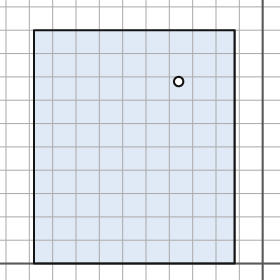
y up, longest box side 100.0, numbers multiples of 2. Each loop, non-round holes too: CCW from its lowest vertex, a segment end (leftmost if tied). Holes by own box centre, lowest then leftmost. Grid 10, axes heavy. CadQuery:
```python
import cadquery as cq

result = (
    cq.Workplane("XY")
    .moveTo(-98.0, 0.0)
    .lineTo(-12.0, 0.0)
    .lineTo(-12.0, 100.0)
    .lineTo(-98.0, 100.0)
    .close()
    .moveTo(-36.0, 78.0)
    .circle(2.0)
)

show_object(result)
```